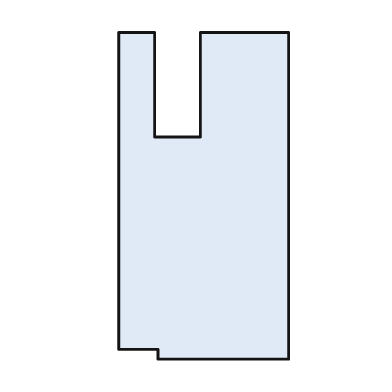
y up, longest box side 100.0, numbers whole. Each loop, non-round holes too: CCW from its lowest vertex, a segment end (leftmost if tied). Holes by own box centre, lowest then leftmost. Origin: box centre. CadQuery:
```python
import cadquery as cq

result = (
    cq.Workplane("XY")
    .moveTo(-14.0, -50.0)
    .lineTo(26.0, -50.0)
    .lineTo(26.0, 50.0)
    .lineTo(-1.0, 50.0)
    .lineTo(-1.0, 18.0)
    .lineTo(-15.0, 18.0)
    .lineTo(-15.0, 50.0)
    .lineTo(-26.0, 50.0)
    .lineTo(-26.0, -47.0)
    .lineTo(-14.0, -47.0)
    .close()
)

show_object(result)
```